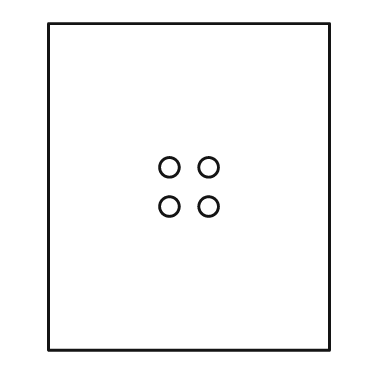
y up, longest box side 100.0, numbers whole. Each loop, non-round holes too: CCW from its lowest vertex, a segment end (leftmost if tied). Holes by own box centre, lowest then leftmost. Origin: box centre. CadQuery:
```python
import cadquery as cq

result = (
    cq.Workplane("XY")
    .moveTo(-43.0, -50.0)
    .lineTo(43.0, -50.0)
    .lineTo(43.0, 50.0)
    .lineTo(-43.0, 50.0)
    .close()
    .moveTo(-6.0, -6.0)
    .circle(3.0)
    .moveTo(6.0, -6.0)
    .circle(3.0)
    .moveTo(-6.0, 6.0)
    .circle(3.0)
    .moveTo(6.0, 6.0)
    .circle(3.0)
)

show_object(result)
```